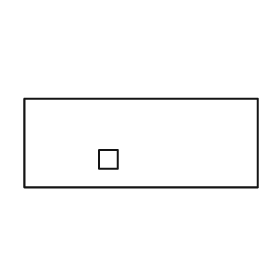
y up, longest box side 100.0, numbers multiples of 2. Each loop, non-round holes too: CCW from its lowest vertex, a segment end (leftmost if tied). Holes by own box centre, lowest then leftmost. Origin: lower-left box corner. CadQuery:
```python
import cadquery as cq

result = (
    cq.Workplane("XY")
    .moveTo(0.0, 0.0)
    .lineTo(100.0, 0.0)
    .lineTo(100.0, 38.0)
    .lineTo(0.0, 38.0)
    .close()
    .moveTo(32.0, 8.0)
    .lineTo(40.0, 8.0)
    .lineTo(40.0, 16.0)
    .lineTo(32.0, 16.0)
    .close()
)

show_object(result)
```